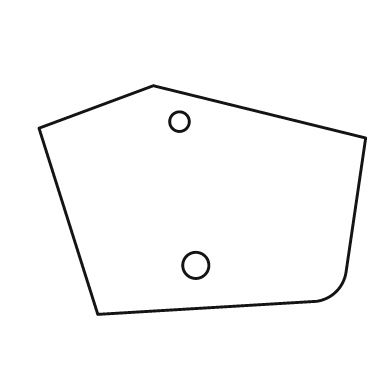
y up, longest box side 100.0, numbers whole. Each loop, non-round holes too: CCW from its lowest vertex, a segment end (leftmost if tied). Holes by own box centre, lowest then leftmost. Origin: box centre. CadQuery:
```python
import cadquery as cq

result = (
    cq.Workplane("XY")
    .moveTo(-32.0, -35.0)
    .lineTo(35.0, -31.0)
    .threePointArc((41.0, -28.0), (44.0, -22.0))
    .lineTo(50.0, 19.0)
    .lineTo(-15.0, 35.0)
    .lineTo(-50.0, 22.0)
    .close()
    .moveTo(-2.0, -20.0)
    .circle(4.0)
    .moveTo(-7.0, 24.0)
    .circle(3.0)
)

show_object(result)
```